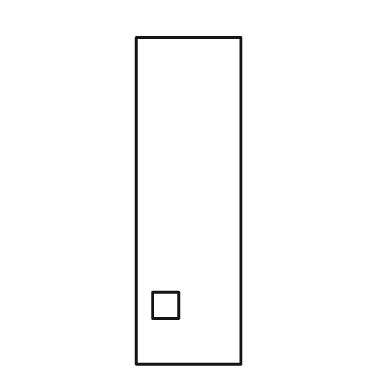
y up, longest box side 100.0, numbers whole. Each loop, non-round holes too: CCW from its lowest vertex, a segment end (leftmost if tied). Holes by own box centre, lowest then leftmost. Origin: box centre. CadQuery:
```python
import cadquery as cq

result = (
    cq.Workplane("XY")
    .moveTo(-16.0, -50.0)
    .lineTo(16.0, -50.0)
    .lineTo(16.0, 50.0)
    .lineTo(-16.0, 50.0)
    .close()
    .moveTo(-11.0, -36.0)
    .lineTo(-3.0, -36.0)
    .lineTo(-3.0, -28.0)
    .lineTo(-11.0, -28.0)
    .close()
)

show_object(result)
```